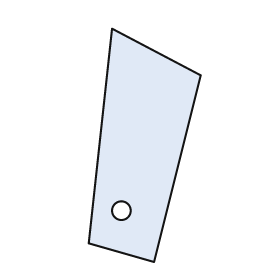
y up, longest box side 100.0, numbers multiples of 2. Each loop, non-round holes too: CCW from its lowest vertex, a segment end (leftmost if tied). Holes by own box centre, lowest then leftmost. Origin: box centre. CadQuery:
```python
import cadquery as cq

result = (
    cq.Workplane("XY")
    .moveTo(4.0, -50.0)
    .lineTo(24.0, 30.0)
    .lineTo(-14.0, 50.0)
    .lineTo(-24.0, -42.0)
    .close()
    .moveTo(-10.0, -28.0)
    .circle(4.0)
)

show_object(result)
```